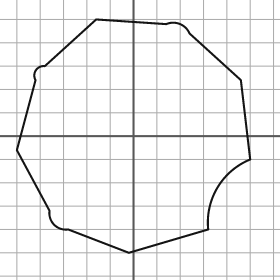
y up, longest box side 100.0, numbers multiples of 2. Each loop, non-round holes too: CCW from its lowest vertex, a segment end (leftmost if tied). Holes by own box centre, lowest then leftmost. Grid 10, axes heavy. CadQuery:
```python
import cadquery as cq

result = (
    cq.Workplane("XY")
    .moveTo(-2.0, -50.0)
    .lineTo(32.0, -40.0)
    .threePointArc((36.0, -22.0), (50.0, -10.0))
    .lineTo(46.0, 24.0)
    .lineTo(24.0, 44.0)
    .threePointArc((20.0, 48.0), (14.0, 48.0))
    .lineTo(-16.0, 50.0)
    .lineTo(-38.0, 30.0)
    .threePointArc((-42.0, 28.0), (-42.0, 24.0))
    .lineTo(-50.0, -6.0)
    .lineTo(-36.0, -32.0)
    .threePointArc((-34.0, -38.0), (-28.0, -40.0))
    .close()
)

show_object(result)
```